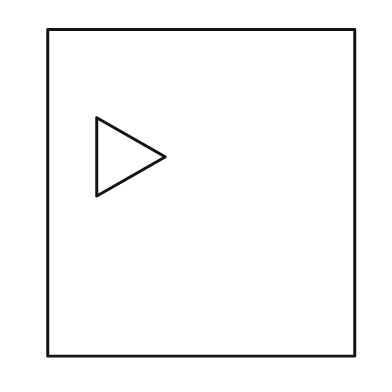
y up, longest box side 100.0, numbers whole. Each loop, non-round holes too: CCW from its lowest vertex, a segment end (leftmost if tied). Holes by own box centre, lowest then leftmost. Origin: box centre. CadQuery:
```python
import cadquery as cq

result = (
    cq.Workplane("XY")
    .moveTo(-47.0, -50.0)
    .lineTo(47.0, -50.0)
    .lineTo(47.0, 50.0)
    .lineTo(-47.0, 50.0)
    .close()
    .moveTo(-32.0, -1.0)
    .lineTo(-11.0, 11.0)
    .lineTo(-32.0, 23.0)
    .close()
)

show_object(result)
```